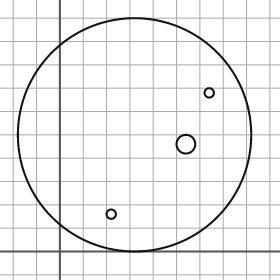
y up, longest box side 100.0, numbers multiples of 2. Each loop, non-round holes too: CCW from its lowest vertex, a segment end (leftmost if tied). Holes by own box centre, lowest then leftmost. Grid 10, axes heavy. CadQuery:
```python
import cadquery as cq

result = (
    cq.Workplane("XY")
    .moveTo(32.0, 50.0)
    .circle(50.0)
    .moveTo(22.0, 16.0)
    .circle(2.0)
    .moveTo(54.0, 46.0)
    .circle(4.0)
    .moveTo(64.0, 68.0)
    .circle(2.0)
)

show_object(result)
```